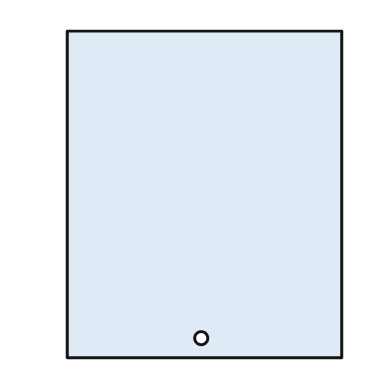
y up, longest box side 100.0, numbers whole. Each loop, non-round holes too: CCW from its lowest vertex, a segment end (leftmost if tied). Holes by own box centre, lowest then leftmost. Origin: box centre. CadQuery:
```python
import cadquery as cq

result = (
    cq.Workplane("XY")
    .moveTo(-42.0, -50.0)
    .lineTo(42.0, -50.0)
    .lineTo(42.0, 50.0)
    .lineTo(-42.0, 50.0)
    .close()
    .moveTo(-1.0, -44.0)
    .circle(2.0)
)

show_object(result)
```